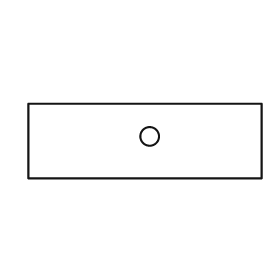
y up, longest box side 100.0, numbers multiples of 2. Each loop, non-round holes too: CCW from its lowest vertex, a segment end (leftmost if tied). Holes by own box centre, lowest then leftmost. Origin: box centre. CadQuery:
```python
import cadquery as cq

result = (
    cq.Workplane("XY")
    .moveTo(-50.0, -16.0)
    .lineTo(50.0, -16.0)
    .lineTo(50.0, 16.0)
    .lineTo(-50.0, 16.0)
    .close()
    .moveTo(2.0, 2.0)
    .circle(4.0)
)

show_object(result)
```